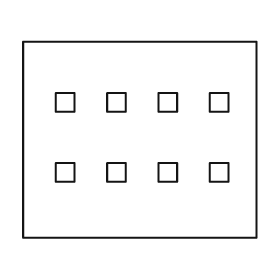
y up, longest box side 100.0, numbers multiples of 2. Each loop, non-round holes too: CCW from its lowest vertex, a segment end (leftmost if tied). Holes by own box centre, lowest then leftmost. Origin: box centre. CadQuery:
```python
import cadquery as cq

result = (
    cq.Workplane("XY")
    .moveTo(-50.0, -42.0)
    .lineTo(50.0, -42.0)
    .lineTo(50.0, 42.0)
    .lineTo(-50.0, 42.0)
    .close()
    .moveTo(-36.0, -18.0)
    .lineTo(-28.0, -18.0)
    .lineTo(-28.0, -10.0)
    .lineTo(-36.0, -10.0)
    .close()
    .moveTo(-14.0, -18.0)
    .lineTo(-6.0, -18.0)
    .lineTo(-6.0, -10.0)
    .lineTo(-14.0, -10.0)
    .close()
    .moveTo(8.0, -18.0)
    .lineTo(16.0, -18.0)
    .lineTo(16.0, -10.0)
    .lineTo(8.0, -10.0)
    .close()
    .moveTo(30.0, -18.0)
    .lineTo(38.0, -18.0)
    .lineTo(38.0, -10.0)
    .lineTo(30.0, -10.0)
    .close()
    .moveTo(-36.0, 12.0)
    .lineTo(-28.0, 12.0)
    .lineTo(-28.0, 20.0)
    .lineTo(-36.0, 20.0)
    .close()
    .moveTo(-14.0, 12.0)
    .lineTo(-6.0, 12.0)
    .lineTo(-6.0, 20.0)
    .lineTo(-14.0, 20.0)
    .close()
    .moveTo(8.0, 12.0)
    .lineTo(16.0, 12.0)
    .lineTo(16.0, 20.0)
    .lineTo(8.0, 20.0)
    .close()
    .moveTo(30.0, 12.0)
    .lineTo(38.0, 12.0)
    .lineTo(38.0, 20.0)
    .lineTo(30.0, 20.0)
    .close()
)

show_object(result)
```